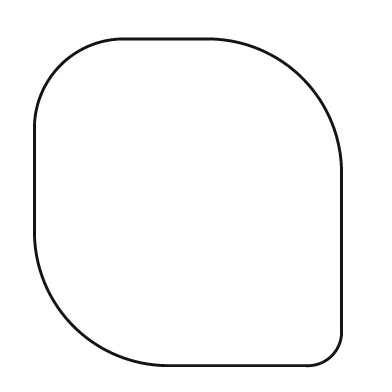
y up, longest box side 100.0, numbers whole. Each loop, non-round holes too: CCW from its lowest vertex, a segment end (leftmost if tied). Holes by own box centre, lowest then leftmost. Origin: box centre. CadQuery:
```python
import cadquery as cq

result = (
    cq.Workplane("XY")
    .moveTo(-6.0, -50.0)
    .lineTo(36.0, -50.0)
    .threePointArc((44.0, -47.0), (47.0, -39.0))
    .lineTo(47.0, 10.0)
    .threePointArc((35.0, 38.0), (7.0, 50.0))
    .lineTo(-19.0, 50.0)
    .threePointArc((-39.0, 42.0), (-47.0, 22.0))
    .lineTo(-47.0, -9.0)
    .threePointArc((-35.0, -38.0), (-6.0, -50.0))
    .close()
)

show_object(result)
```